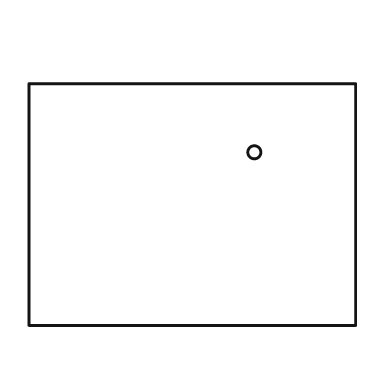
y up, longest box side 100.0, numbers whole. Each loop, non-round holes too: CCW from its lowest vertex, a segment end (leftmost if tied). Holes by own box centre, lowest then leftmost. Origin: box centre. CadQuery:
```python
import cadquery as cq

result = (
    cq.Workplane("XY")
    .moveTo(-50.0, -37.0)
    .lineTo(50.0, -37.0)
    .lineTo(50.0, 37.0)
    .lineTo(-50.0, 37.0)
    .close()
    .moveTo(19.0, 16.0)
    .circle(2.0)
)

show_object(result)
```